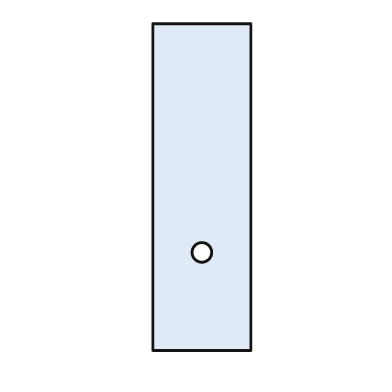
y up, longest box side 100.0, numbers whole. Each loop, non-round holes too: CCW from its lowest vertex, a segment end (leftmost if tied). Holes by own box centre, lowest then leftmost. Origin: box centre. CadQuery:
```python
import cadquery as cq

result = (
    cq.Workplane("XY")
    .moveTo(-15.0, -50.0)
    .lineTo(15.0, -50.0)
    .lineTo(15.0, 50.0)
    .lineTo(-15.0, 50.0)
    .close()
    .moveTo(0.0, -20.0)
    .circle(3.0)
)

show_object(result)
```